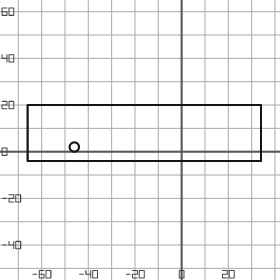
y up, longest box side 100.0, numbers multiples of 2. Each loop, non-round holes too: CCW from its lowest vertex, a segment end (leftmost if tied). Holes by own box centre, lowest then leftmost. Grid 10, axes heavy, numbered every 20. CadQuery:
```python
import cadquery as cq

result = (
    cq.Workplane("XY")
    .moveTo(-66.0, -4.0)
    .lineTo(34.0, -4.0)
    .lineTo(34.0, 20.0)
    .lineTo(-66.0, 20.0)
    .close()
    .moveTo(-46.0, 2.0)
    .circle(2.0)
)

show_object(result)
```